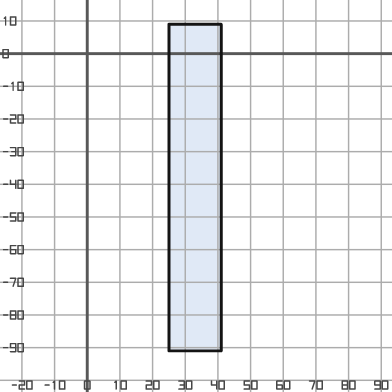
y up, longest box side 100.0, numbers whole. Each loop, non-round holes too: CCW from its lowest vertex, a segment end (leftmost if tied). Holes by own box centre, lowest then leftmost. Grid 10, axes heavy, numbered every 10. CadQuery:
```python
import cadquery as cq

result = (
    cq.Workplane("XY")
    .moveTo(25.0, -91.0)
    .lineTo(41.0, -91.0)
    .lineTo(41.0, 9.0)
    .lineTo(25.0, 9.0)
    .close()
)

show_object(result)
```